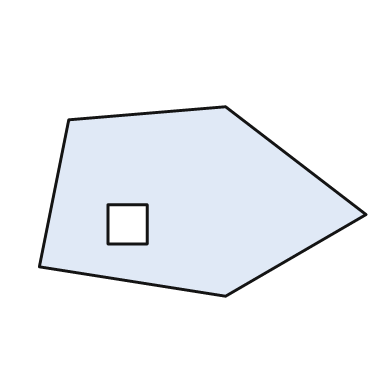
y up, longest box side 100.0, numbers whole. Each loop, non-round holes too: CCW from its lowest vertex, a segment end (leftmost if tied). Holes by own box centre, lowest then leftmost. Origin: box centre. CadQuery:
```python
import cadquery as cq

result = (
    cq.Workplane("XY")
    .moveTo(7.0, -29.0)
    .lineTo(50.0, -4.0)
    .lineTo(7.0, 29.0)
    .lineTo(-41.0, 25.0)
    .lineTo(-50.0, -20.0)
    .close()
    .moveTo(-29.0, -13.0)
    .lineTo(-17.0, -13.0)
    .lineTo(-17.0, -1.0)
    .lineTo(-29.0, -1.0)
    .close()
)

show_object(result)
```